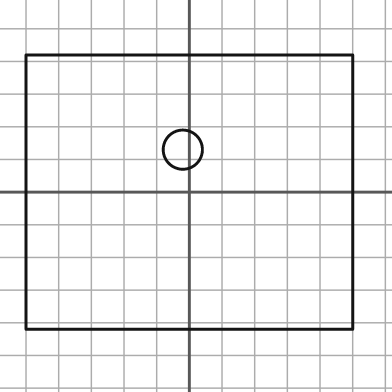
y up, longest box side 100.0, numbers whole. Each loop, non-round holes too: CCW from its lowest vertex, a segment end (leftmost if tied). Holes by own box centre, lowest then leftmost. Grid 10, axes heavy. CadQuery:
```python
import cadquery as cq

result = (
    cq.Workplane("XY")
    .moveTo(-50.0, -42.0)
    .lineTo(50.0, -42.0)
    .lineTo(50.0, 42.0)
    .lineTo(-50.0, 42.0)
    .close()
    .moveTo(-2.0, 13.0)
    .circle(6.0)
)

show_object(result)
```